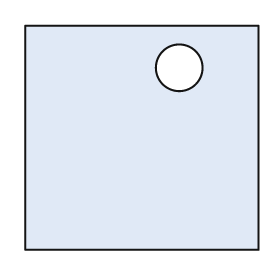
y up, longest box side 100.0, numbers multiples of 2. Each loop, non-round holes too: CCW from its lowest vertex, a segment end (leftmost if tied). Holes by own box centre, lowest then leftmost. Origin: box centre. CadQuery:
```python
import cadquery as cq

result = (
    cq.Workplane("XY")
    .moveTo(-50.0, -48.0)
    .lineTo(50.0, -48.0)
    .lineTo(50.0, 48.0)
    .lineTo(-50.0, 48.0)
    .close()
    .moveTo(16.0, 30.0)
    .circle(10.0)
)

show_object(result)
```